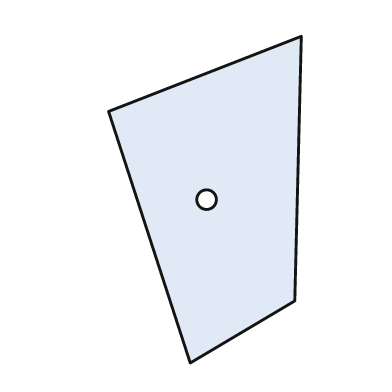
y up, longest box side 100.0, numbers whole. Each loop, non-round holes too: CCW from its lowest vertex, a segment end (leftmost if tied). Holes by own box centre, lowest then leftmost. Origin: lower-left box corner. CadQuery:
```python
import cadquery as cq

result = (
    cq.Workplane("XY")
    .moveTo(25.0, 0.0)
    .lineTo(57.0, 19.0)
    .lineTo(59.0, 100.0)
    .lineTo(0.0, 77.0)
    .close()
    .moveTo(30.0, 50.0)
    .circle(3.0)
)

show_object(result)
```